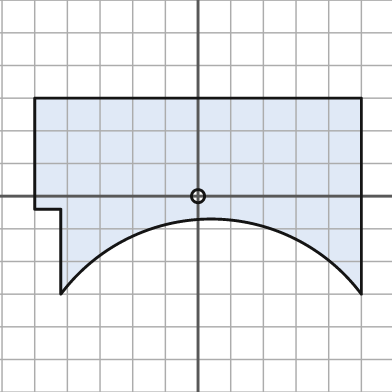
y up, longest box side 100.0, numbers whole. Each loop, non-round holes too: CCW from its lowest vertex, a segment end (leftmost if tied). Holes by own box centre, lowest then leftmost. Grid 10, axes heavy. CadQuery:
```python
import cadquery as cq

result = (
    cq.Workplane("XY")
    .moveTo(-42.0, -30.0)
    .threePointArc((4.0, -7.0), (50.0, -30.0))
    .lineTo(50.0, 30.0)
    .lineTo(-50.0, 30.0)
    .lineTo(-50.0, -4.0)
    .lineTo(-42.0, -4.0)
    .close()
    .moveTo(0.0, 0.0)
    .circle(2.0)
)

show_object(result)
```